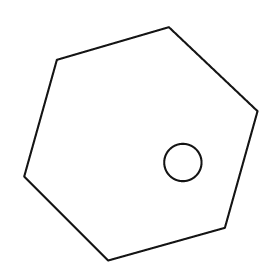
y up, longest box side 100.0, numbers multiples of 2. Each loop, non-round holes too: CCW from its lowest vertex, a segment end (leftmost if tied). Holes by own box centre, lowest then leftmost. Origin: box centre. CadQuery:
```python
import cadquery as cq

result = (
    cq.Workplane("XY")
    .moveTo(-14.0, -50.0)
    .lineTo(36.0, -36.0)
    .lineTo(50.0, 14.0)
    .lineTo(12.0, 50.0)
    .lineTo(-36.0, 36.0)
    .lineTo(-50.0, -14.0)
    .close()
    .moveTo(18.0, -8.0)
    .circle(8.0)
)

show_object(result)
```